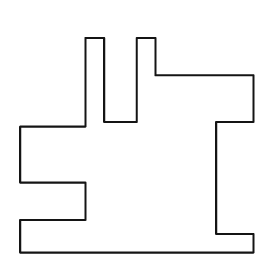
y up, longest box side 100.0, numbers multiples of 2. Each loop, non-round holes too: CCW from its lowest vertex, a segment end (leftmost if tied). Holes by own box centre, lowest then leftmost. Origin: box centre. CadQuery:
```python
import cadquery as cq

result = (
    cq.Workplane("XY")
    .moveTo(-50.0, -46.0)
    .lineTo(50.0, -46.0)
    .lineTo(50.0, -38.0)
    .lineTo(34.0, -38.0)
    .lineTo(34.0, 10.0)
    .lineTo(50.0, 10.0)
    .lineTo(50.0, 30.0)
    .lineTo(8.0, 30.0)
    .lineTo(8.0, 46.0)
    .lineTo(0.0, 46.0)
    .lineTo(0.0, 10.0)
    .lineTo(-14.0, 10.0)
    .lineTo(-14.0, 46.0)
    .lineTo(-22.0, 46.0)
    .lineTo(-22.0, 8.0)
    .lineTo(-50.0, 8.0)
    .lineTo(-50.0, -16.0)
    .lineTo(-22.0, -16.0)
    .lineTo(-22.0, -32.0)
    .lineTo(-50.0, -32.0)
    .close()
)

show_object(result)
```